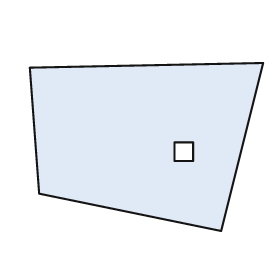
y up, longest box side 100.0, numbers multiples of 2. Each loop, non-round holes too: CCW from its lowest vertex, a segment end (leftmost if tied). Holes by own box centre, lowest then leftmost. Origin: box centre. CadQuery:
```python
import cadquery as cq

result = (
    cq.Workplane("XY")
    .moveTo(32.0, -36.0)
    .lineTo(50.0, 36.0)
    .lineTo(-50.0, 34.0)
    .lineTo(-46.0, -20.0)
    .close()
    .moveTo(12.0, -6.0)
    .lineTo(20.0, -6.0)
    .lineTo(20.0, 2.0)
    .lineTo(12.0, 2.0)
    .close()
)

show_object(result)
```